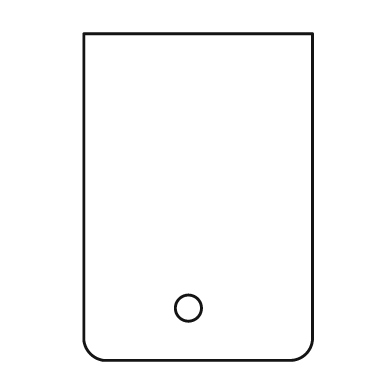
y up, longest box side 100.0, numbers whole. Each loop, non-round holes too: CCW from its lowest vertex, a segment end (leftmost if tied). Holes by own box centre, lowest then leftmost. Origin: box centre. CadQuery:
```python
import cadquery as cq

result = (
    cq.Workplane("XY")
    .moveTo(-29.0, -50.0)
    .lineTo(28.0, -50.0)
    .threePointArc((33.0, -48.0), (35.0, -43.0))
    .lineTo(35.0, 50.0)
    .lineTo(-35.0, 50.0)
    .lineTo(-35.0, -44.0)
    .threePointArc((-33.0, -48.0), (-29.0, -50.0))
    .close()
    .moveTo(-3.0, -34.0)
    .circle(4.0)
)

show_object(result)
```